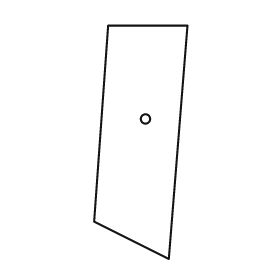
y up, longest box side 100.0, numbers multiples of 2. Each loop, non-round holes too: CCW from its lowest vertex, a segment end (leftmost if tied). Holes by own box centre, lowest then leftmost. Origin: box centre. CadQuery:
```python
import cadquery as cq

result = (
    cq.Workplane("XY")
    .moveTo(12.0, -50.0)
    .lineTo(20.0, 50.0)
    .lineTo(-14.0, 50.0)
    .lineTo(-20.0, -34.0)
    .close()
    .moveTo(2.0, 10.0)
    .circle(2.0)
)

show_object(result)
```